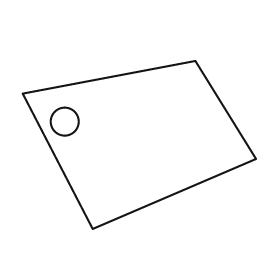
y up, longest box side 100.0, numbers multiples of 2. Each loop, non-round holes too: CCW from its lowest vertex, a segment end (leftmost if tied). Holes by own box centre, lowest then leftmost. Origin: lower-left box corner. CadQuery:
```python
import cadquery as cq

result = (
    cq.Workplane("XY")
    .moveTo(30.0, 0.0)
    .lineTo(100.0, 30.0)
    .lineTo(74.0, 72.0)
    .lineTo(0.0, 58.0)
    .close()
    .moveTo(18.0, 46.0)
    .circle(6.0)
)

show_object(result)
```